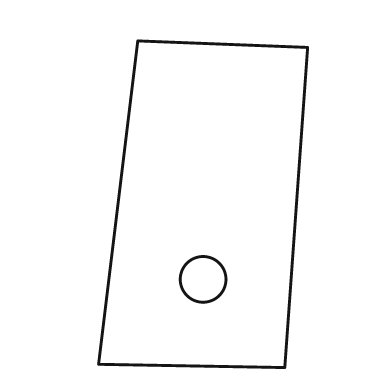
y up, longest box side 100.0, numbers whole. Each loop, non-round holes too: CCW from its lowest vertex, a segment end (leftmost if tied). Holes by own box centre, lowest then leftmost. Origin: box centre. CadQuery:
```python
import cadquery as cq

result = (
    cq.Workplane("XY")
    .moveTo(25.0, -50.0)
    .lineTo(32.0, 48.0)
    .lineTo(-20.0, 50.0)
    .lineTo(-32.0, -49.0)
    .close()
    .moveTo(0.0, -23.0)
    .circle(7.0)
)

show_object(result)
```